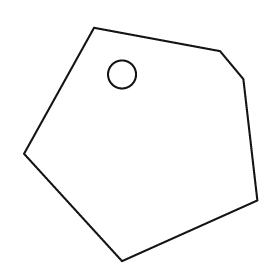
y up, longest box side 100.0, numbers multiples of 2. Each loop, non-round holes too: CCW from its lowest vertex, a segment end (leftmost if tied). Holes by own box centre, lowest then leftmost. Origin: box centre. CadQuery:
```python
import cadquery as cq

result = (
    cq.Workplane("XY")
    .moveTo(-8.0, -50.0)
    .lineTo(50.0, -24.0)
    .lineTo(44.0, 28.0)
    .lineTo(34.0, 40.0)
    .lineTo(-20.0, 50.0)
    .lineTo(-50.0, -4.0)
    .close()
    .moveTo(-8.0, 30.0)
    .circle(6.0)
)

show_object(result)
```